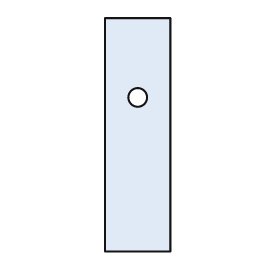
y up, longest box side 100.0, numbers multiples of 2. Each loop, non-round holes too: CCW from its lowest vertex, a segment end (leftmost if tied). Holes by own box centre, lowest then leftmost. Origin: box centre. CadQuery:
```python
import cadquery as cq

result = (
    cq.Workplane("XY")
    .moveTo(-14.0, -50.0)
    .lineTo(14.0, -50.0)
    .lineTo(14.0, 50.0)
    .lineTo(-14.0, 50.0)
    .close()
    .moveTo(0.0, 16.0)
    .circle(4.0)
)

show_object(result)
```